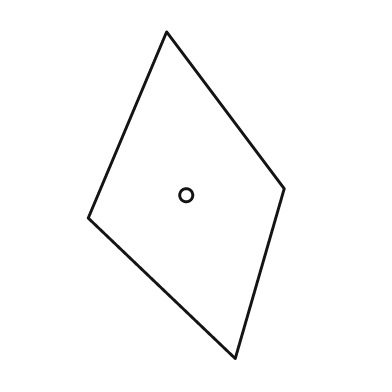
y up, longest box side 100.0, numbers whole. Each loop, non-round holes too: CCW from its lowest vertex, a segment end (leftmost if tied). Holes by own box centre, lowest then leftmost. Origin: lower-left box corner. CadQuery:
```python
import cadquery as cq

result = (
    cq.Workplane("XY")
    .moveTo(45.0, 0.0)
    .lineTo(60.0, 52.0)
    .lineTo(24.0, 100.0)
    .lineTo(0.0, 43.0)
    .close()
    .moveTo(30.0, 50.0)
    .circle(2.0)
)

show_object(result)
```